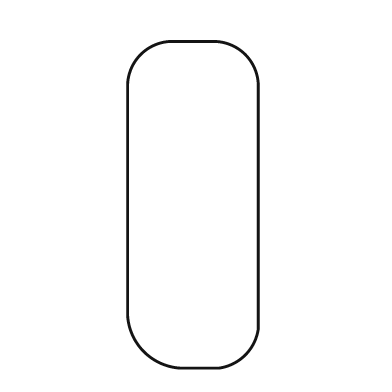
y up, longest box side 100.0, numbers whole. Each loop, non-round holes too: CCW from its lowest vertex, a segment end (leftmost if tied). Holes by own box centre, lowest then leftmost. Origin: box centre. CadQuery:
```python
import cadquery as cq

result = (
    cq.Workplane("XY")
    .moveTo(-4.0, -50.0)
    .lineTo(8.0, -50.0)
    .threePointArc((16.0, -46.0), (20.0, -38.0))
    .lineTo(20.0, 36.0)
    .threePointArc((16.0, 46.0), (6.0, 50.0))
    .lineTo(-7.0, 50.0)
    .threePointArc((-16.0, 46.0), (-20.0, 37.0))
    .lineTo(-20.0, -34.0)
    .threePointArc((-15.0, -45.0), (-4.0, -50.0))
    .close()
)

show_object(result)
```